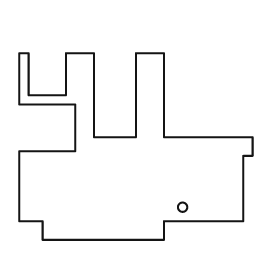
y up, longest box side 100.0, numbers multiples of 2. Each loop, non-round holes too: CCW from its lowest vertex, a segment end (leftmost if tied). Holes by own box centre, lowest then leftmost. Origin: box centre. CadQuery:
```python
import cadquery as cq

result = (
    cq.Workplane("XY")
    .moveTo(-40.0, -40.0)
    .lineTo(12.0, -40.0)
    .lineTo(12.0, -32.0)
    .lineTo(46.0, -32.0)
    .lineTo(46.0, -4.0)
    .lineTo(50.0, -4.0)
    .lineTo(50.0, 4.0)
    .lineTo(12.0, 4.0)
    .lineTo(12.0, 40.0)
    .lineTo(0.0, 40.0)
    .lineTo(0.0, 4.0)
    .lineTo(-18.0, 4.0)
    .lineTo(-18.0, 40.0)
    .lineTo(-30.0, 40.0)
    .lineTo(-30.0, 22.0)
    .lineTo(-46.0, 22.0)
    .lineTo(-46.0, 40.0)
    .lineTo(-50.0, 40.0)
    .lineTo(-50.0, 18.0)
    .lineTo(-26.0, 18.0)
    .lineTo(-26.0, -2.0)
    .lineTo(-50.0, -2.0)
    .lineTo(-50.0, -32.0)
    .lineTo(-40.0, -32.0)
    .close()
    .moveTo(20.0, -26.0)
    .circle(2.0)
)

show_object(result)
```